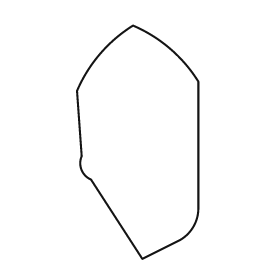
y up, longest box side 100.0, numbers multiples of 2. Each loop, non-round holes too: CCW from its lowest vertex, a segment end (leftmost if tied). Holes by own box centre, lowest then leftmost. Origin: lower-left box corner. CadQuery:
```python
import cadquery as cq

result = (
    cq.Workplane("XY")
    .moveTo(28.0, 0.0)
    .lineTo(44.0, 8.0)
    .threePointArc((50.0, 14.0), (52.0, 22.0))
    .lineTo(52.0, 76.0)
    .threePointArc((40.0, 90.0), (24.0, 100.0))
    .threePointArc((10.0, 88.0), (0.0, 72.0))
    .lineTo(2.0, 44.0)
    .threePointArc((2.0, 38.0), (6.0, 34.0))
    .close()
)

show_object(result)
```